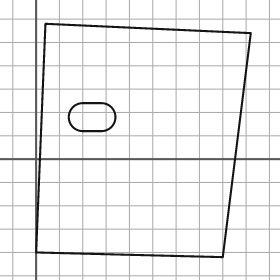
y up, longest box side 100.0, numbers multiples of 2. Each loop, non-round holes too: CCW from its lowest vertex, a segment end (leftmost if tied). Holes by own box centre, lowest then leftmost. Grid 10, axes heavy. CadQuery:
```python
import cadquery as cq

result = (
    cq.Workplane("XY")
    .moveTo(80.0, -42.0)
    .lineTo(92.0, 54.0)
    .lineTo(4.0, 58.0)
    .lineTo(0.0, -40.0)
    .close()
    .moveTo(20.0, 12.0)
    .lineTo(28.0, 12.0)
    .threePointArc((34.0, 18.0), (28.0, 24.0))
    .lineTo(20.0, 24.0)
    .threePointArc((14.0, 18.0), (20.0, 12.0))
    .close()
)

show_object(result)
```